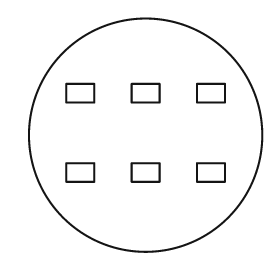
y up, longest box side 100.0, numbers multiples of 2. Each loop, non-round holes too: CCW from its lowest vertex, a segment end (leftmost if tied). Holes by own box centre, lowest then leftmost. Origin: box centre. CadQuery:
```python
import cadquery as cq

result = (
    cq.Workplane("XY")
    .moveTo(0.0, 0.0)
    .circle(50.0)
    .moveTo(-34.0, -20.0)
    .lineTo(-22.0, -20.0)
    .lineTo(-22.0, -12.0)
    .lineTo(-34.0, -12.0)
    .close()
    .moveTo(-6.0, -20.0)
    .lineTo(6.0, -20.0)
    .lineTo(6.0, -12.0)
    .lineTo(-6.0, -12.0)
    .close()
    .moveTo(22.0, -20.0)
    .lineTo(34.0, -20.0)
    .lineTo(34.0, -12.0)
    .lineTo(22.0, -12.0)
    .close()
    .moveTo(-34.0, 14.0)
    .lineTo(-22.0, 14.0)
    .lineTo(-22.0, 22.0)
    .lineTo(-34.0, 22.0)
    .close()
    .moveTo(-6.0, 14.0)
    .lineTo(6.0, 14.0)
    .lineTo(6.0, 22.0)
    .lineTo(-6.0, 22.0)
    .close()
    .moveTo(22.0, 14.0)
    .lineTo(34.0, 14.0)
    .lineTo(34.0, 22.0)
    .lineTo(22.0, 22.0)
    .close()
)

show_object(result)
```